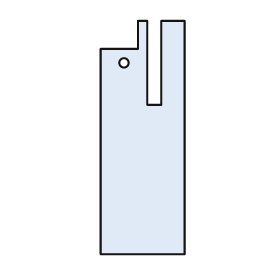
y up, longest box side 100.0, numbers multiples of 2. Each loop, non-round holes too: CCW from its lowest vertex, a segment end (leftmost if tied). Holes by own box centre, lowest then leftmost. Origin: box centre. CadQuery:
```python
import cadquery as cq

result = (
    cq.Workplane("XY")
    .moveTo(-18.0, -50.0)
    .lineTo(18.0, -50.0)
    .lineTo(18.0, 50.0)
    .lineTo(8.0, 50.0)
    .lineTo(8.0, 14.0)
    .lineTo(2.0, 14.0)
    .lineTo(2.0, 50.0)
    .lineTo(-2.0, 50.0)
    .lineTo(-2.0, 38.0)
    .lineTo(-18.0, 38.0)
    .close()
    .moveTo(-8.0, 32.0)
    .circle(2.0)
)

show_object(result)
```